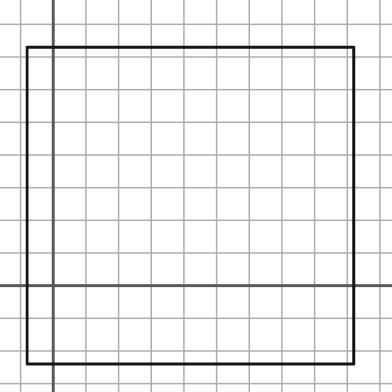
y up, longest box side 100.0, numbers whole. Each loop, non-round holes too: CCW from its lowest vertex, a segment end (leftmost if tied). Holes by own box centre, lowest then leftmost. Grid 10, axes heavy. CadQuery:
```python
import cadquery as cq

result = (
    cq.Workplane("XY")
    .moveTo(-8.0, -24.0)
    .lineTo(92.0, -24.0)
    .lineTo(92.0, 73.0)
    .lineTo(-8.0, 73.0)
    .close()
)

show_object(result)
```